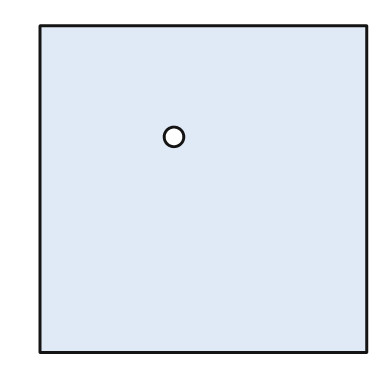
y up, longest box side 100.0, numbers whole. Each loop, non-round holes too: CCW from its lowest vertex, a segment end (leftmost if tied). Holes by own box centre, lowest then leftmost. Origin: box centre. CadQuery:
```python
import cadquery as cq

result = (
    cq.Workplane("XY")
    .moveTo(-50.0, -50.0)
    .lineTo(50.0, -50.0)
    .lineTo(50.0, 50.0)
    .lineTo(-50.0, 50.0)
    .close()
    .moveTo(-9.0, 16.0)
    .circle(3.0)
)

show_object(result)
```